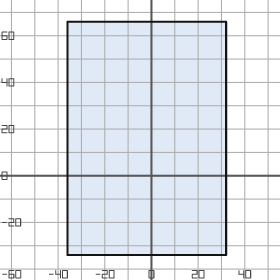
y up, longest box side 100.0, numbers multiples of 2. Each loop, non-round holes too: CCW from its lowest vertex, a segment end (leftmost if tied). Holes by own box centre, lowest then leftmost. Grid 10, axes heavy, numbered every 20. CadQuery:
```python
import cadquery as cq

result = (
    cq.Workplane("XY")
    .moveTo(-36.0, -34.0)
    .lineTo(32.0, -34.0)
    .lineTo(32.0, 66.0)
    .lineTo(-36.0, 66.0)
    .close()
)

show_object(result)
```